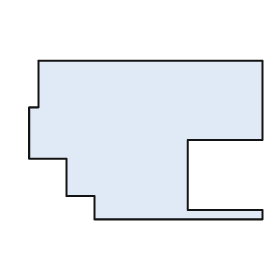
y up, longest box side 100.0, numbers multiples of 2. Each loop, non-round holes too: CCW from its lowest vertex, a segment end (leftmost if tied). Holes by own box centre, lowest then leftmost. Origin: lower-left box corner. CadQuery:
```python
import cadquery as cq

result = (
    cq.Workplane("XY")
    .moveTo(28.0, 0.0)
    .lineTo(100.0, 0.0)
    .lineTo(100.0, 4.0)
    .lineTo(68.0, 4.0)
    .lineTo(68.0, 34.0)
    .lineTo(100.0, 34.0)
    .lineTo(100.0, 68.0)
    .lineTo(4.0, 68.0)
    .lineTo(4.0, 48.0)
    .lineTo(0.0, 48.0)
    .lineTo(0.0, 26.0)
    .lineTo(16.0, 26.0)
    .lineTo(16.0, 10.0)
    .lineTo(28.0, 10.0)
    .close()
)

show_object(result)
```